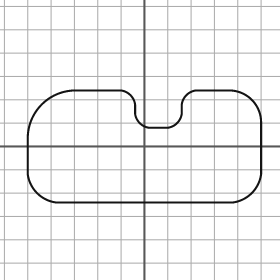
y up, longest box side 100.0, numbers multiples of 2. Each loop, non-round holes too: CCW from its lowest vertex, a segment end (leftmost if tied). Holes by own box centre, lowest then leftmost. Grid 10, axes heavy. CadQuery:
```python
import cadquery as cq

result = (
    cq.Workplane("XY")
    .moveTo(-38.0, -24.0)
    .lineTo(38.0, -24.0)
    .threePointArc((46.0, -20.0), (50.0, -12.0))
    .lineTo(50.0, 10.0)
    .threePointArc((46.0, 20.0), (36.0, 24.0))
    .lineTo(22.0, 24.0)
    .threePointArc((18.0, 22.0), (16.0, 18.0))
    .lineTo(16.0, 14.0)
    .threePointArc((14.0, 10.0), (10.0, 8.0))
    .lineTo(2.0, 8.0)
    .threePointArc((-2.0, 10.0), (-4.0, 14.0))
    .lineTo(-4.0, 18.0)
    .threePointArc((-6.0, 22.0), (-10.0, 24.0))
    .lineTo(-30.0, 24.0)
    .threePointArc((-44.0, 18.0), (-50.0, 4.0))
    .lineTo(-50.0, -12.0)
    .threePointArc((-46.0, -20.0), (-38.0, -24.0))
    .close()
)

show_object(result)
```